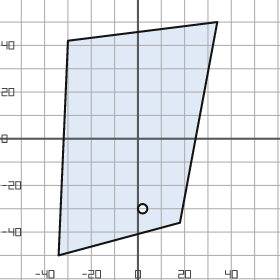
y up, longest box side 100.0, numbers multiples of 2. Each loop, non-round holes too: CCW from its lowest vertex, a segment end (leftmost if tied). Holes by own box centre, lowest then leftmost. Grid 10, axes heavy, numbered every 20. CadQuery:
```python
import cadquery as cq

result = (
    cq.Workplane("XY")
    .moveTo(-34.0, -50.0)
    .lineTo(18.0, -36.0)
    .lineTo(34.0, 50.0)
    .lineTo(-30.0, 42.0)
    .close()
    .moveTo(2.0, -30.0)
    .circle(2.0)
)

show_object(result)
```